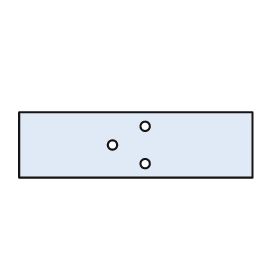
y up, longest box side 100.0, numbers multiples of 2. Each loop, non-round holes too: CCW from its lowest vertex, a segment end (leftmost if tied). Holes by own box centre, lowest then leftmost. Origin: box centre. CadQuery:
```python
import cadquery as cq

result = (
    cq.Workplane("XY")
    .moveTo(-50.0, -14.0)
    .lineTo(50.0, -14.0)
    .lineTo(50.0, 14.0)
    .lineTo(-50.0, 14.0)
    .close()
    .moveTo(4.0, -8.0)
    .circle(2.0)
    .moveTo(-10.0, 0.0)
    .circle(2.0)
    .moveTo(4.0, 8.0)
    .circle(2.0)
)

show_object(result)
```